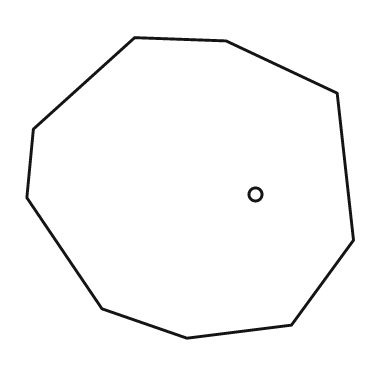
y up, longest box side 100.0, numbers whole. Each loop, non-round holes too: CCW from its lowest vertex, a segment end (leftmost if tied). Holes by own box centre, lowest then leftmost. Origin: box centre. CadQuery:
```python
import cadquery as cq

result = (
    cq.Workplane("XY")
    .moveTo(-1.0, -46.0)
    .lineTo(31.0, -42.0)
    .lineTo(50.0, -16.0)
    .lineTo(45.0, 29.0)
    .lineTo(11.0, 45.0)
    .lineTo(-17.0, 46.0)
    .lineTo(-48.0, 18.0)
    .lineTo(-50.0, -3.0)
    .lineTo(-27.0, -37.0)
    .close()
    .moveTo(20.0, -2.0)
    .circle(2.0)
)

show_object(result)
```